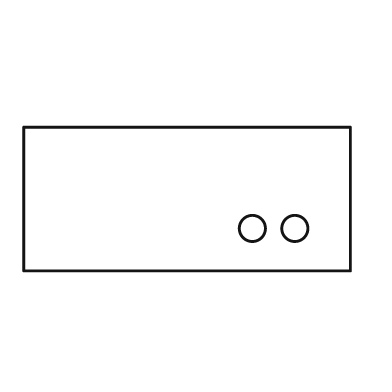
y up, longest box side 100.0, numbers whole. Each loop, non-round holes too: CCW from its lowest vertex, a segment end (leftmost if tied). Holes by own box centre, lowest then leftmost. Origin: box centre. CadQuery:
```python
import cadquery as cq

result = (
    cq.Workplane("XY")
    .moveTo(-50.0, -22.0)
    .lineTo(50.0, -22.0)
    .lineTo(50.0, 22.0)
    .lineTo(-50.0, 22.0)
    .close()
    .moveTo(20.0, -9.0)
    .circle(4.0)
    .moveTo(33.0, -9.0)
    .circle(4.0)
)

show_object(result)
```